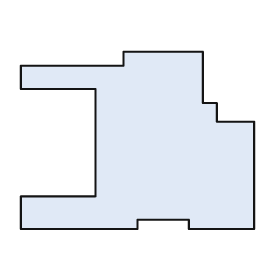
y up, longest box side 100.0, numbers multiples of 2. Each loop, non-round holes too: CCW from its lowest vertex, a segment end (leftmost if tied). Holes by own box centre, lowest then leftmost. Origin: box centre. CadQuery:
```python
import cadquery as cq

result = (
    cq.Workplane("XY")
    .moveTo(-50.0, -38.0)
    .lineTo(0.0, -38.0)
    .lineTo(0.0, -34.0)
    .lineTo(22.0, -34.0)
    .lineTo(22.0, -38.0)
    .lineTo(50.0, -38.0)
    .lineTo(50.0, 8.0)
    .lineTo(34.0, 8.0)
    .lineTo(34.0, 16.0)
    .lineTo(28.0, 16.0)
    .lineTo(28.0, 38.0)
    .lineTo(-6.0, 38.0)
    .lineTo(-6.0, 32.0)
    .lineTo(-50.0, 32.0)
    .lineTo(-50.0, 22.0)
    .lineTo(-18.0, 22.0)
    .lineTo(-18.0, -24.0)
    .lineTo(-50.0, -24.0)
    .close()
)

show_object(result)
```